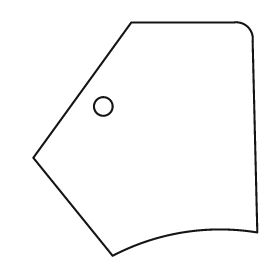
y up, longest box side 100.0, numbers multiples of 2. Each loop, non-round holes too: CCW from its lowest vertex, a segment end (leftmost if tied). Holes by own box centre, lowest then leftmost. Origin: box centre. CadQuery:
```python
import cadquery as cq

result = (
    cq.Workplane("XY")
    .moveTo(-14.0, -50.0)
    .threePointArc((16.0, -40.0), (48.0, -40.0))
    .lineTo(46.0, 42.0)
    .threePointArc((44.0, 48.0), (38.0, 50.0))
    .lineTo(-6.0, 50.0)
    .lineTo(-48.0, -8.0)
    .close()
    .moveTo(-18.0, 14.0)
    .circle(4.0)
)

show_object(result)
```